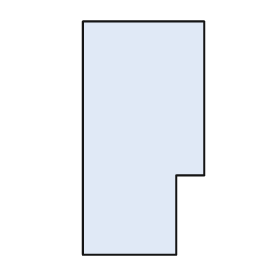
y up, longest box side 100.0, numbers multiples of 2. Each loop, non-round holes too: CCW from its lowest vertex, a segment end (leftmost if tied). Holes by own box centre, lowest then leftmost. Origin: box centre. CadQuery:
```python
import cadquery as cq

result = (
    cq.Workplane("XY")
    .moveTo(-26.0, -50.0)
    .lineTo(14.0, -50.0)
    .lineTo(14.0, -16.0)
    .lineTo(26.0, -16.0)
    .lineTo(26.0, 50.0)
    .lineTo(-26.0, 50.0)
    .close()
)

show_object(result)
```